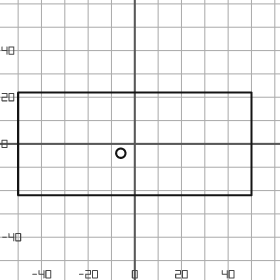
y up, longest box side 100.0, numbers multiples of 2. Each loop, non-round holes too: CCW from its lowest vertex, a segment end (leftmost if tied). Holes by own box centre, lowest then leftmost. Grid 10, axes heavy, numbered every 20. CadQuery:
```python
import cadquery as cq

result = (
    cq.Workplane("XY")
    .moveTo(-50.0, -22.0)
    .lineTo(50.0, -22.0)
    .lineTo(50.0, 22.0)
    .lineTo(-50.0, 22.0)
    .close()
    .moveTo(-6.0, -4.0)
    .circle(2.0)
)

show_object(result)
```